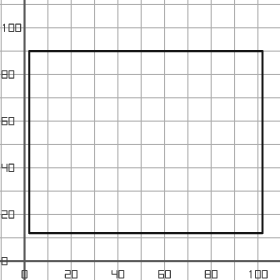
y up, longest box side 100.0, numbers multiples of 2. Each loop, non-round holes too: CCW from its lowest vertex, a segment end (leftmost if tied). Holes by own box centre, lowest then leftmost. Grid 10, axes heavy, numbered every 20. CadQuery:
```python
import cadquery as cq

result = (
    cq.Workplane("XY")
    .moveTo(2.0, 12.0)
    .lineTo(102.0, 12.0)
    .lineTo(102.0, 90.0)
    .lineTo(2.0, 90.0)
    .close()
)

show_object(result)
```